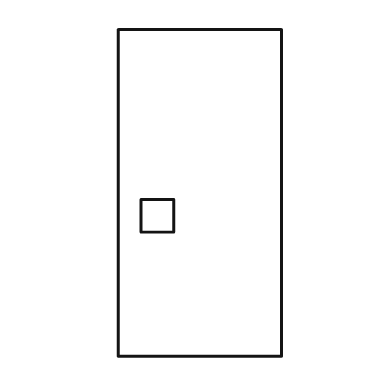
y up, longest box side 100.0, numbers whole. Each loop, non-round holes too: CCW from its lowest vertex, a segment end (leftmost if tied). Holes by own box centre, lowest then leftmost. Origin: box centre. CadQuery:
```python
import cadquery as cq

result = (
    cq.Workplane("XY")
    .moveTo(-25.0, -50.0)
    .lineTo(25.0, -50.0)
    .lineTo(25.0, 50.0)
    .lineTo(-25.0, 50.0)
    .close()
    .moveTo(-18.0, -12.0)
    .lineTo(-8.0, -12.0)
    .lineTo(-8.0, -2.0)
    .lineTo(-18.0, -2.0)
    .close()
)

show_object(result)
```